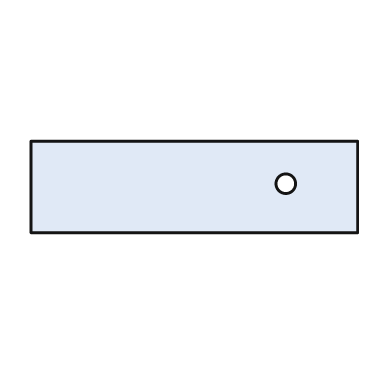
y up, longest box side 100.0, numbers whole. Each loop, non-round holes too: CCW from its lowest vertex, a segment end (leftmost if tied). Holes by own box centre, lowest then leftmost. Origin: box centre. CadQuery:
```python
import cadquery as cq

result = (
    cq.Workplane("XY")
    .moveTo(-50.0, -14.0)
    .lineTo(50.0, -14.0)
    .lineTo(50.0, 14.0)
    .lineTo(-50.0, 14.0)
    .close()
    .moveTo(28.0, 1.0)
    .circle(3.0)
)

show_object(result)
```